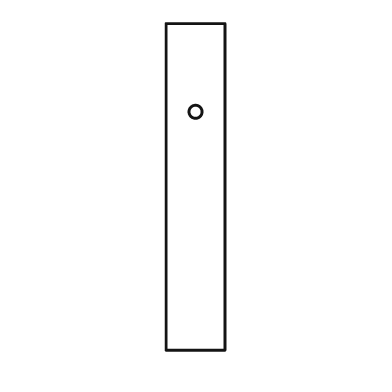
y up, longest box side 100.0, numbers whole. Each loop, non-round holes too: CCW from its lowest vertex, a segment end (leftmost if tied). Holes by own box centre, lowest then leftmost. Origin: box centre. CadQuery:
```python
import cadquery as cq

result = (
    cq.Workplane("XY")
    .moveTo(-9.0, -50.0)
    .lineTo(9.0, -50.0)
    .lineTo(9.0, 50.0)
    .lineTo(-9.0, 50.0)
    .close()
    .moveTo(0.0, 23.0)
    .circle(2.0)
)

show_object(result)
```